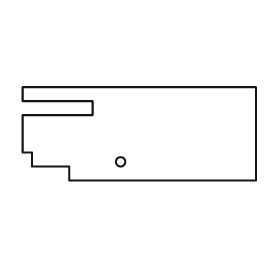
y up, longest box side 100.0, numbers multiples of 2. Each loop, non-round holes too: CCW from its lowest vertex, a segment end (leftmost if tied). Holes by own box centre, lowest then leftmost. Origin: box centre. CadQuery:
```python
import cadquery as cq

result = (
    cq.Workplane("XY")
    .moveTo(-30.0, -20.0)
    .lineTo(50.0, -20.0)
    .lineTo(50.0, 20.0)
    .lineTo(-50.0, 20.0)
    .lineTo(-50.0, 14.0)
    .lineTo(-20.0, 14.0)
    .lineTo(-20.0, 8.0)
    .lineTo(-50.0, 8.0)
    .lineTo(-50.0, -8.0)
    .lineTo(-46.0, -8.0)
    .lineTo(-46.0, -14.0)
    .lineTo(-30.0, -14.0)
    .close()
    .moveTo(-8.0, -12.0)
    .circle(2.0)
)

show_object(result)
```